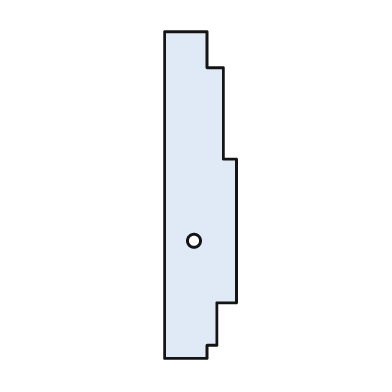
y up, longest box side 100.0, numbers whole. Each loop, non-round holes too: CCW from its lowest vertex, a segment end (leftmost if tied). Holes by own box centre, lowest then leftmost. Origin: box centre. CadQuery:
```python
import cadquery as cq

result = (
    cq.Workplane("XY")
    .moveTo(-11.0, -50.0)
    .lineTo(2.0, -50.0)
    .lineTo(2.0, -46.0)
    .lineTo(5.0, -46.0)
    .lineTo(5.0, -33.0)
    .lineTo(11.0, -33.0)
    .lineTo(11.0, 11.0)
    .lineTo(7.0, 11.0)
    .lineTo(7.0, 39.0)
    .lineTo(2.0, 39.0)
    .lineTo(2.0, 50.0)
    .lineTo(-11.0, 50.0)
    .close()
    .moveTo(-2.0, -14.0)
    .circle(2.0)
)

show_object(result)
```